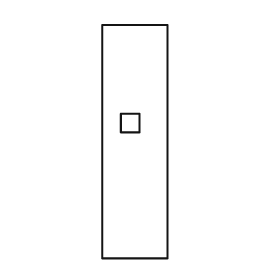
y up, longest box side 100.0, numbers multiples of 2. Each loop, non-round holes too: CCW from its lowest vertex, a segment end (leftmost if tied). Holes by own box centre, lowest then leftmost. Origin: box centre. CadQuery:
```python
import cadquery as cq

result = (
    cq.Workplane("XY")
    .moveTo(-14.0, -50.0)
    .lineTo(14.0, -50.0)
    .lineTo(14.0, 50.0)
    .lineTo(-14.0, 50.0)
    .close()
    .moveTo(-6.0, 4.0)
    .lineTo(2.0, 4.0)
    .lineTo(2.0, 12.0)
    .lineTo(-6.0, 12.0)
    .close()
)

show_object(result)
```